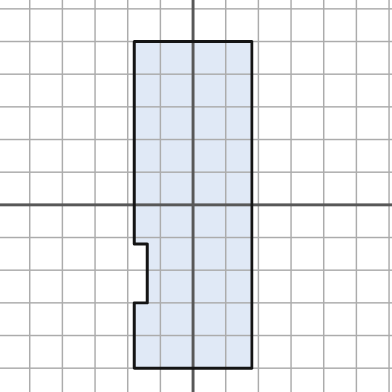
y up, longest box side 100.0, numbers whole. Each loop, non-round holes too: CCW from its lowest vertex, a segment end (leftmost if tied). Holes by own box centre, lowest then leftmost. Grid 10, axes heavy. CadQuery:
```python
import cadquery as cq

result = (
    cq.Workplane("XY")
    .moveTo(-18.0, -50.0)
    .lineTo(18.0, -50.0)
    .lineTo(18.0, 50.0)
    .lineTo(-18.0, 50.0)
    .lineTo(-18.0, -12.0)
    .lineTo(-14.0, -12.0)
    .lineTo(-14.0, -30.0)
    .lineTo(-18.0, -30.0)
    .close()
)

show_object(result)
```